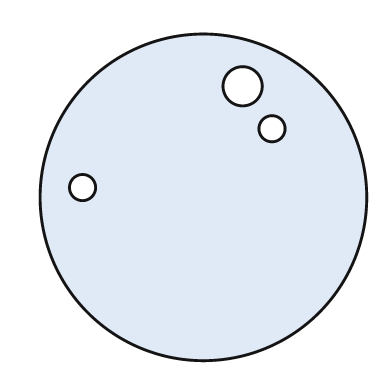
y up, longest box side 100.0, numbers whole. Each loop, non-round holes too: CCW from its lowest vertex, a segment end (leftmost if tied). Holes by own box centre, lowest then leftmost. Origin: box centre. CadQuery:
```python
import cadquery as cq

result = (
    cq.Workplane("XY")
    .moveTo(0.0, 0.0)
    .circle(50.0)
    .moveTo(-37.0, 3.0)
    .circle(4.0)
    .moveTo(21.0, 21.0)
    .circle(4.0)
    .moveTo(12.0, 34.0)
    .circle(6.0)
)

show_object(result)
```